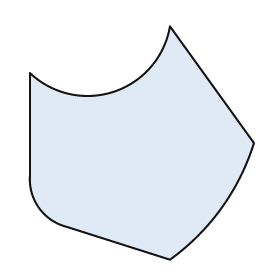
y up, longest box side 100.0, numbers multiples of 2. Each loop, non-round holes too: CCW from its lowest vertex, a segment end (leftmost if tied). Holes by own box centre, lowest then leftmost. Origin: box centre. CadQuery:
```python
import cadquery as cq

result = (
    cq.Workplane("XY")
    .moveTo(12.0, -50.0)
    .threePointArc((34.0, -28.0), (48.0, 0.0))
    .lineTo(12.0, 50.0)
    .threePointArc((-12.0, 22.0), (-48.0, 30.0))
    .lineTo(-48.0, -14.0)
    .threePointArc((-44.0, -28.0), (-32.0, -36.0))
    .close()
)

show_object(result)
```